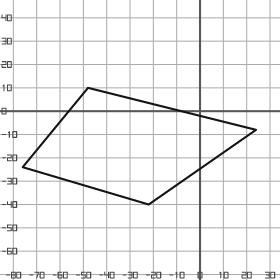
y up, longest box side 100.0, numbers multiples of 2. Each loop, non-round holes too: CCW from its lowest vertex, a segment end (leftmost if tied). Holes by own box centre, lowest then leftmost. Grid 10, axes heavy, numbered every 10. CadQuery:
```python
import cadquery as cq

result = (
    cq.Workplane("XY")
    .moveTo(-22.0, -40.0)
    .lineTo(24.0, -8.0)
    .lineTo(-48.0, 10.0)
    .lineTo(-76.0, -24.0)
    .close()
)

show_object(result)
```